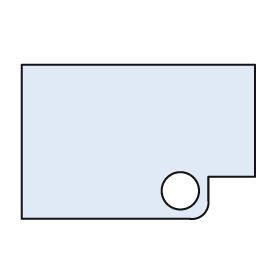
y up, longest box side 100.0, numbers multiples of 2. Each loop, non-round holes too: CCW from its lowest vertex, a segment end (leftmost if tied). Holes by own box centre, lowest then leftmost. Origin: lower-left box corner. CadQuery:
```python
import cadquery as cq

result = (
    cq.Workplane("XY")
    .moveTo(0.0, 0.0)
    .lineTo(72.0, 0.0)
    .threePointArc((78.0, 2.0), (80.0, 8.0))
    .lineTo(80.0, 18.0)
    .lineTo(100.0, 18.0)
    .lineTo(100.0, 66.0)
    .lineTo(0.0, 66.0)
    .close()
    .moveTo(68.0, 12.0)
    .circle(8.0)
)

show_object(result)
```